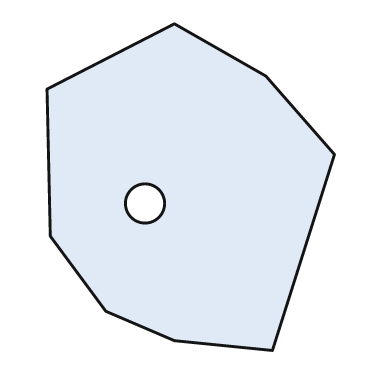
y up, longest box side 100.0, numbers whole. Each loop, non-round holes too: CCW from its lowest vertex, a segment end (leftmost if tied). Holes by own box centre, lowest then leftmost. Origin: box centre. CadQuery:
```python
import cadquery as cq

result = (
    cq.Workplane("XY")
    .moveTo(25.0, -50.0)
    .lineTo(44.0, 10.0)
    .lineTo(23.0, 34.0)
    .lineTo(-5.0, 50.0)
    .lineTo(-44.0, 30.0)
    .lineTo(-43.0, -15.0)
    .lineTo(-26.0, -38.0)
    .lineTo(-5.0, -47.0)
    .close()
    .moveTo(-14.0, -5.0)
    .circle(6.0)
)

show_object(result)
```